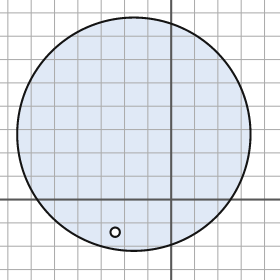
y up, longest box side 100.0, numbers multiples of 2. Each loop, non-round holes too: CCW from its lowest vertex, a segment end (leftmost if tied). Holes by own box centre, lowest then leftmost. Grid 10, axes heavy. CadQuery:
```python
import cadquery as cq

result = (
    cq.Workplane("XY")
    .moveTo(-16.0, 28.0)
    .circle(50.0)
    .moveTo(-24.0, -14.0)
    .circle(2.0)
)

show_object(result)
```